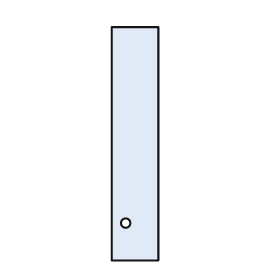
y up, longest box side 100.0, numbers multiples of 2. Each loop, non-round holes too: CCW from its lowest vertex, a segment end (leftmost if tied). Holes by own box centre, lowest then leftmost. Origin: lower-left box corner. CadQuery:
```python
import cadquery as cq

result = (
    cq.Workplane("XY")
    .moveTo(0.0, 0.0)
    .lineTo(20.0, 0.0)
    .lineTo(20.0, 100.0)
    .lineTo(0.0, 100.0)
    .close()
    .moveTo(6.0, 16.0)
    .circle(2.0)
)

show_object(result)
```